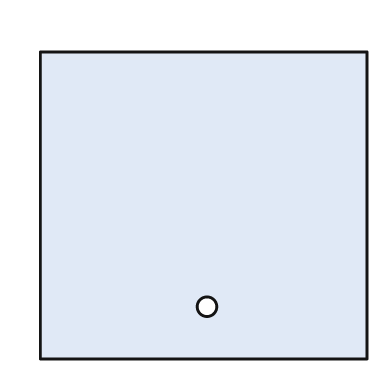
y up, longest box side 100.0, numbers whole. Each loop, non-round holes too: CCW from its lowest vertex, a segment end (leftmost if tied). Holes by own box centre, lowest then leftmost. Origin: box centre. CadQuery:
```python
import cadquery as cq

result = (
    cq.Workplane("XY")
    .moveTo(-50.0, -47.0)
    .lineTo(50.0, -47.0)
    .lineTo(50.0, 47.0)
    .lineTo(-50.0, 47.0)
    .close()
    .moveTo(1.0, -31.0)
    .circle(3.0)
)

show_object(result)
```